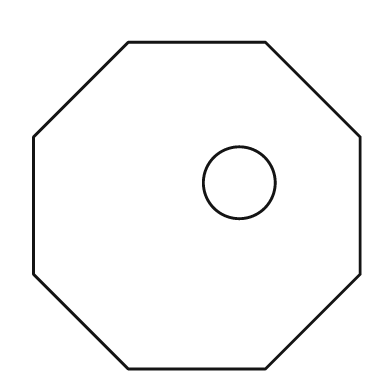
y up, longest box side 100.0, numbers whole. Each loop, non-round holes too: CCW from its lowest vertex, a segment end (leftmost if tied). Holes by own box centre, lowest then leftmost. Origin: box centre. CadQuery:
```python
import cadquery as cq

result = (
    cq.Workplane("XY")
    .moveTo(-21.0, -50.0)
    .lineTo(21.0, -50.0)
    .lineTo(50.0, -21.0)
    .lineTo(50.0, 21.0)
    .lineTo(21.0, 50.0)
    .lineTo(-21.0, 50.0)
    .lineTo(-50.0, 21.0)
    .lineTo(-50.0, -21.0)
    .close()
    .moveTo(13.0, 7.0)
    .circle(11.0)
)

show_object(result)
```